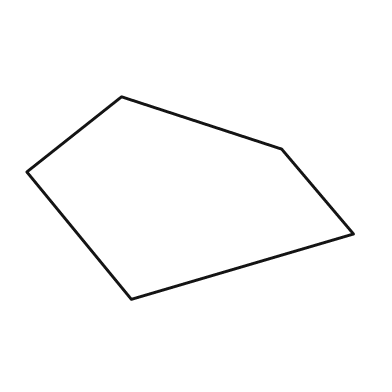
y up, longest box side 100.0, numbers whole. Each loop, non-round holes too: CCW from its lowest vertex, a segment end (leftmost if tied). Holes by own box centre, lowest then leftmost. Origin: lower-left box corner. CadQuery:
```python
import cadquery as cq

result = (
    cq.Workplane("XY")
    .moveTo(32.0, 0.0)
    .lineTo(100.0, 20.0)
    .lineTo(78.0, 46.0)
    .lineTo(29.0, 62.0)
    .lineTo(0.0, 39.0)
    .close()
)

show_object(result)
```